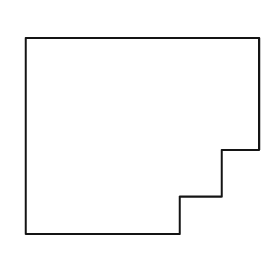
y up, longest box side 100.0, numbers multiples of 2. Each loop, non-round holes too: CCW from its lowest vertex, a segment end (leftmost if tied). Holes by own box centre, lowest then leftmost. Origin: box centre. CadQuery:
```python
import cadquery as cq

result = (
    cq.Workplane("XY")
    .moveTo(-50.0, -42.0)
    .lineTo(16.0, -42.0)
    .lineTo(16.0, -26.0)
    .lineTo(34.0, -26.0)
    .lineTo(34.0, -6.0)
    .lineTo(50.0, -6.0)
    .lineTo(50.0, 42.0)
    .lineTo(-50.0, 42.0)
    .close()
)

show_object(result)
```